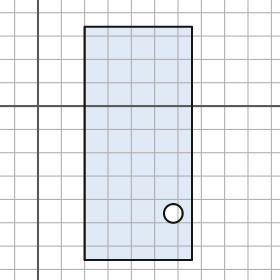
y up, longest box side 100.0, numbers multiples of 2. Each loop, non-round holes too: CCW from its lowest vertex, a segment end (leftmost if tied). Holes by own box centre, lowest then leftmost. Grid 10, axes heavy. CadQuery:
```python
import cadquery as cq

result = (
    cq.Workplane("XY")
    .moveTo(20.0, -66.0)
    .lineTo(66.0, -66.0)
    .lineTo(66.0, 34.0)
    .lineTo(20.0, 34.0)
    .close()
    .moveTo(58.0, -46.0)
    .circle(4.0)
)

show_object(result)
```